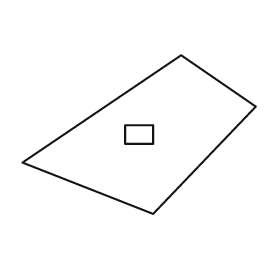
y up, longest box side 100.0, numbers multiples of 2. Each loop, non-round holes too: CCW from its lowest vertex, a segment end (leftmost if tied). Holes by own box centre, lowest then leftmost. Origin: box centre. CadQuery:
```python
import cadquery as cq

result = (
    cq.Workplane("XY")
    .moveTo(6.0, -34.0)
    .lineTo(50.0, 12.0)
    .lineTo(18.0, 34.0)
    .lineTo(-50.0, -12.0)
    .close()
    .moveTo(-6.0, -4.0)
    .lineTo(6.0, -4.0)
    .lineTo(6.0, 4.0)
    .lineTo(-6.0, 4.0)
    .close()
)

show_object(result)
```